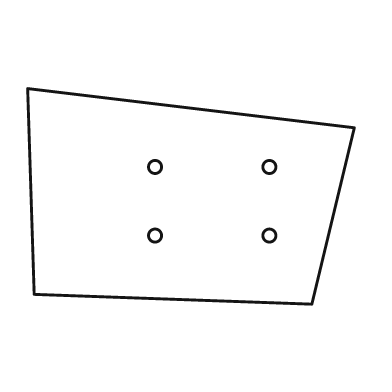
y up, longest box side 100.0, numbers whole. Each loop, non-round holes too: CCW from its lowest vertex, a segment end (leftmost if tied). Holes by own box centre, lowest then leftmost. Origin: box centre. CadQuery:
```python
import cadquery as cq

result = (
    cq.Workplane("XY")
    .moveTo(37.0, -33.0)
    .lineTo(50.0, 21.0)
    .lineTo(-50.0, 33.0)
    .lineTo(-48.0, -30.0)
    .close()
    .moveTo(-11.0, -12.0)
    .circle(2.0)
    .moveTo(24.0, -12.0)
    .circle(2.0)
    .moveTo(-11.0, 9.0)
    .circle(2.0)
    .moveTo(24.0, 9.0)
    .circle(2.0)
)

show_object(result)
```